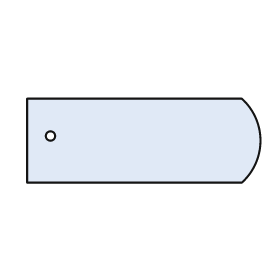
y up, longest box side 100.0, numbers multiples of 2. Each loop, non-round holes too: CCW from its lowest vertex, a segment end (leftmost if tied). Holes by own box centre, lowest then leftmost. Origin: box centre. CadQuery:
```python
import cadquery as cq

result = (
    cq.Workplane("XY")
    .moveTo(-50.0, -18.0)
    .lineTo(42.0, -18.0)
    .threePointArc((50.0, 0.0), (42.0, 18.0))
    .lineTo(-50.0, 18.0)
    .close()
    .moveTo(-40.0, 2.0)
    .circle(2.0)
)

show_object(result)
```